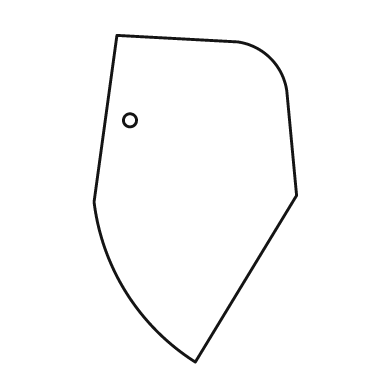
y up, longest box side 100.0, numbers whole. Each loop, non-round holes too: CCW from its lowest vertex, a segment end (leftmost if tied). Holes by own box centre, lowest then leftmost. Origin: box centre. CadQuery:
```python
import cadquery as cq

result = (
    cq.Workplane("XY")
    .moveTo(0.0, -50.0)
    .lineTo(31.0, 1.0)
    .lineTo(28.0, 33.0)
    .threePointArc((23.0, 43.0), (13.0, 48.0))
    .lineTo(-24.0, 50.0)
    .lineTo(-31.0, -1.0)
    .threePointArc((-21.0, -29.0), (0.0, -50.0))
    .close()
    .moveTo(-20.0, 24.0)
    .circle(2.0)
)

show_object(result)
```